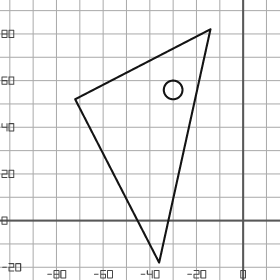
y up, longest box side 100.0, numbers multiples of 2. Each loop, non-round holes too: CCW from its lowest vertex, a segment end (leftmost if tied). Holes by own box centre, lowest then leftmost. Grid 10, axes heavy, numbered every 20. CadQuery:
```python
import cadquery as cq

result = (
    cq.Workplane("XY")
    .moveTo(-36.0, -18.0)
    .lineTo(-14.0, 82.0)
    .lineTo(-72.0, 52.0)
    .close()
    .moveTo(-30.0, 56.0)
    .circle(4.0)
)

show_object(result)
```